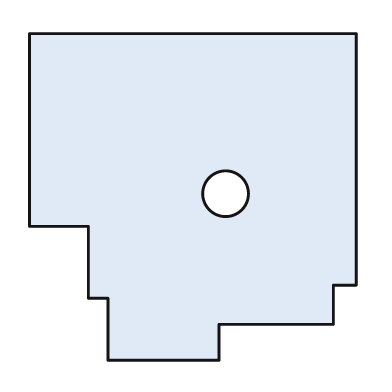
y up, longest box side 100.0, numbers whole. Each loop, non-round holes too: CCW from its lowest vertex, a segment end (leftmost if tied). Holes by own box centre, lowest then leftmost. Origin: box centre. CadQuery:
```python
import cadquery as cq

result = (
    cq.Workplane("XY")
    .moveTo(-26.0, -50.0)
    .lineTo(8.0, -50.0)
    .lineTo(8.0, -39.0)
    .lineTo(43.0, -39.0)
    .lineTo(43.0, -27.0)
    .lineTo(50.0, -27.0)
    .lineTo(50.0, 50.0)
    .lineTo(-50.0, 50.0)
    .lineTo(-50.0, -9.0)
    .lineTo(-32.0, -9.0)
    .lineTo(-32.0, -31.0)
    .lineTo(-26.0, -31.0)
    .close()
    .moveTo(10.0, 1.0)
    .circle(7.0)
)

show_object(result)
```